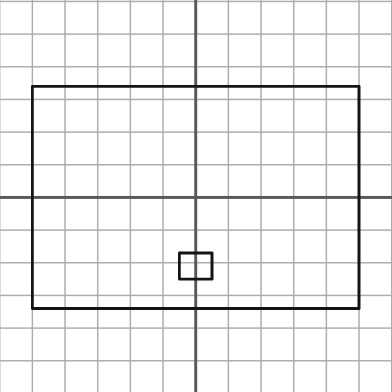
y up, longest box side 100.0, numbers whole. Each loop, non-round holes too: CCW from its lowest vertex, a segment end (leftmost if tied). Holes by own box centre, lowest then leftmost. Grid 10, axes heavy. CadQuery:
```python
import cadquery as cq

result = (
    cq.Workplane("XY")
    .moveTo(-50.0, -34.0)
    .lineTo(50.0, -34.0)
    .lineTo(50.0, 34.0)
    .lineTo(-50.0, 34.0)
    .close()
    .moveTo(-5.0, -25.0)
    .lineTo(5.0, -25.0)
    .lineTo(5.0, -17.0)
    .lineTo(-5.0, -17.0)
    .close()
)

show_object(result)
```